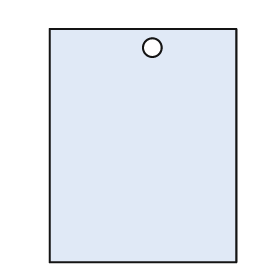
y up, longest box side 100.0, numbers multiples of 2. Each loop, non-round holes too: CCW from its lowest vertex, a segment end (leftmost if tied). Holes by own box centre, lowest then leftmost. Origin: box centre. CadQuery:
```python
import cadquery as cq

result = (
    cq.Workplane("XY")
    .moveTo(-40.0, -50.0)
    .lineTo(40.0, -50.0)
    .lineTo(40.0, 50.0)
    .lineTo(-40.0, 50.0)
    .close()
    .moveTo(4.0, 42.0)
    .circle(4.0)
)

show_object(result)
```